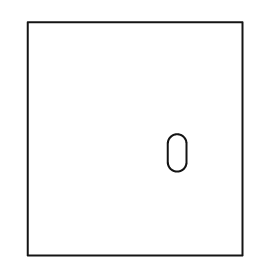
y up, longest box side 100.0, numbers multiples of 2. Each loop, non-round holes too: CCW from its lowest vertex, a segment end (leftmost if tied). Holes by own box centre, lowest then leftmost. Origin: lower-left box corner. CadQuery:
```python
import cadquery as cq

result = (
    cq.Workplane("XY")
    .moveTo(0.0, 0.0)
    .lineTo(92.0, 0.0)
    .lineTo(92.0, 100.0)
    .lineTo(0.0, 100.0)
    .close()
    .moveTo(60.0, 40.0)
    .threePointArc((64.0, 36.0), (68.0, 40.0))
    .lineTo(68.0, 48.0)
    .threePointArc((64.0, 52.0), (60.0, 48.0))
    .close()
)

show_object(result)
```